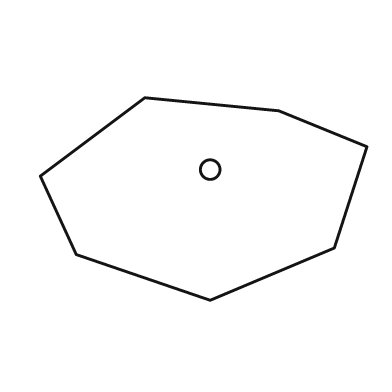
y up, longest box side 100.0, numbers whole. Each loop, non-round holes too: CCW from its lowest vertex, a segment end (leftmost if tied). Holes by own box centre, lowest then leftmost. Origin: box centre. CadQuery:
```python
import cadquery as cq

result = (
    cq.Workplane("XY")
    .moveTo(2.0, -31.0)
    .lineTo(40.0, -15.0)
    .lineTo(50.0, 16.0)
    .lineTo(23.0, 27.0)
    .lineTo(-18.0, 31.0)
    .lineTo(-50.0, 7.0)
    .lineTo(-39.0, -17.0)
    .close()
    .moveTo(2.0, 9.0)
    .circle(3.0)
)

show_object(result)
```